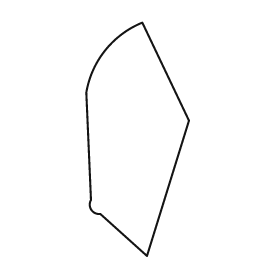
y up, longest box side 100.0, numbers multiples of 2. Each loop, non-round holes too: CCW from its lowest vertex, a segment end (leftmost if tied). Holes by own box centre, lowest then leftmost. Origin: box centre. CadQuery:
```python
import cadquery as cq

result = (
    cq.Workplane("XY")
    .moveTo(4.0, -50.0)
    .lineTo(22.0, 8.0)
    .lineTo(2.0, 50.0)
    .threePointArc((-14.0, 38.0), (-22.0, 20.0))
    .lineTo(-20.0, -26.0)
    .threePointArc((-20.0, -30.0), (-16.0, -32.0))
    .close()
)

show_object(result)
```